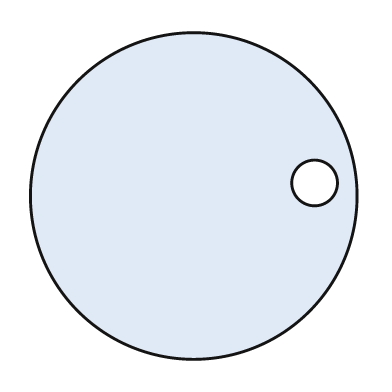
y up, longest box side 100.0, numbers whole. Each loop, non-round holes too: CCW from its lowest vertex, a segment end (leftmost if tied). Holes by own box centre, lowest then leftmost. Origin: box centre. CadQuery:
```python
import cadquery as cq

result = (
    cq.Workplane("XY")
    .moveTo(0.0, 0.0)
    .circle(50.0)
    .moveTo(37.0, 4.0)
    .circle(7.0)
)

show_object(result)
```